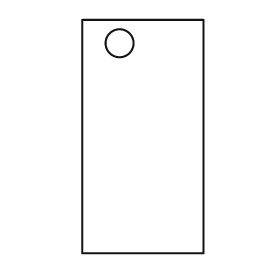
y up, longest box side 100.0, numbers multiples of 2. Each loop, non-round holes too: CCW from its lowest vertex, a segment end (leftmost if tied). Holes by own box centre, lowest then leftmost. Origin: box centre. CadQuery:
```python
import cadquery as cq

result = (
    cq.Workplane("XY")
    .moveTo(-26.0, -50.0)
    .lineTo(26.0, -50.0)
    .lineTo(26.0, 50.0)
    .lineTo(-26.0, 50.0)
    .close()
    .moveTo(-10.0, 40.0)
    .circle(6.0)
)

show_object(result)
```